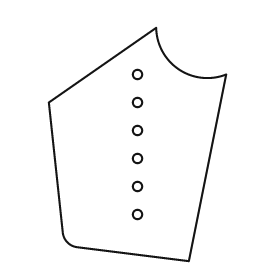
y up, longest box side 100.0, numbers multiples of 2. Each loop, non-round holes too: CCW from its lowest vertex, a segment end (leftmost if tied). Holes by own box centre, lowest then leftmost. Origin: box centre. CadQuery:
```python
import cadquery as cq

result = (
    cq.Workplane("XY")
    .moveTo(22.0, -50.0)
    .lineTo(38.0, 30.0)
    .threePointArc((18.0, 32.0), (8.0, 50.0))
    .lineTo(-38.0, 18.0)
    .lineTo(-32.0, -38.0)
    .threePointArc((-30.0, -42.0), (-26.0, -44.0))
    .close()
    .moveTo(0.0, -30.0)
    .circle(2.0)
    .moveTo(0.0, -18.0)
    .circle(2.0)
    .moveTo(0.0, -6.0)
    .circle(2.0)
    .moveTo(0.0, 6.0)
    .circle(2.0)
    .moveTo(0.0, 18.0)
    .circle(2.0)
    .moveTo(0.0, 30.0)
    .circle(2.0)
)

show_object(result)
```